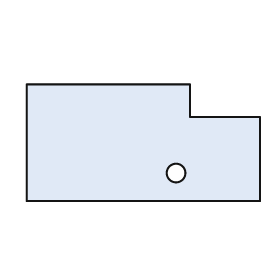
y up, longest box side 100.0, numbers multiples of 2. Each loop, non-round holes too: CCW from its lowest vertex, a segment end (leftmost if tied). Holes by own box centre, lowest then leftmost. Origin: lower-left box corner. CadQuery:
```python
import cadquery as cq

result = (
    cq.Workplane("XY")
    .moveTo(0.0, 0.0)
    .lineTo(100.0, 0.0)
    .lineTo(100.0, 36.0)
    .lineTo(70.0, 36.0)
    .lineTo(70.0, 50.0)
    .lineTo(0.0, 50.0)
    .close()
    .moveTo(64.0, 12.0)
    .circle(4.0)
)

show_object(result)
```